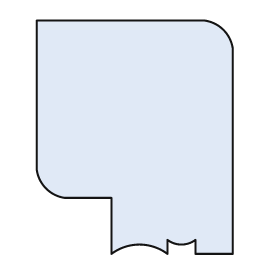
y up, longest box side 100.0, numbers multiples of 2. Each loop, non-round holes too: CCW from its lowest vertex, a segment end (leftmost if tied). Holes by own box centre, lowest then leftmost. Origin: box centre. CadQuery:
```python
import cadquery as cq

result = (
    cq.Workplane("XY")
    .moveTo(-10.0, -50.0)
    .threePointArc((2.0, -46.0), (14.0, -50.0))
    .lineTo(14.0, -44.0)
    .threePointArc((20.0, -46.0), (26.0, -44.0))
    .lineTo(26.0, -50.0)
    .lineTo(42.0, -50.0)
    .lineTo(42.0, 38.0)
    .threePointArc((38.0, 46.0), (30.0, 50.0))
    .lineTo(-42.0, 50.0)
    .lineTo(-42.0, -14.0)
    .threePointArc((-38.0, -22.0), (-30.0, -26.0))
    .lineTo(-10.0, -26.0)
    .close()
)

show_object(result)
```